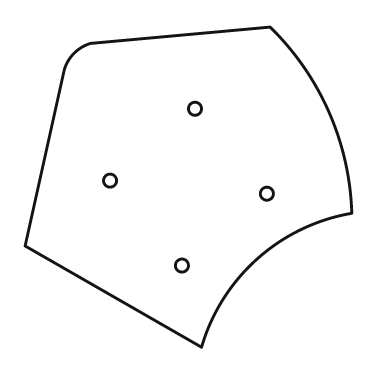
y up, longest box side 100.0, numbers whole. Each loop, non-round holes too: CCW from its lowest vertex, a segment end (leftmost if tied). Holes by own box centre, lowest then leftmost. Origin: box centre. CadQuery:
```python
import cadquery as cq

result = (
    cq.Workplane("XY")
    .moveTo(4.0, -49.0)
    .threePointArc((21.0, -22.0), (50.0, -8.0))
    .threePointArc((43.0, 23.0), (25.0, 49.0))
    .lineTo(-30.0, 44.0)
    .threePointArc((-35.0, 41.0), (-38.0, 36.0))
    .lineTo(-50.0, -18.0)
    .close()
    .moveTo(-2.0, -24.0)
    .circle(2.0)
    .moveTo(24.0, -2.0)
    .circle(2.0)
    .moveTo(-24.0, 2.0)
    .circle(2.0)
    .moveTo(2.0, 24.0)
    .circle(2.0)
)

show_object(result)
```